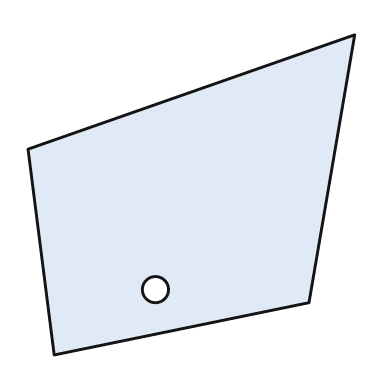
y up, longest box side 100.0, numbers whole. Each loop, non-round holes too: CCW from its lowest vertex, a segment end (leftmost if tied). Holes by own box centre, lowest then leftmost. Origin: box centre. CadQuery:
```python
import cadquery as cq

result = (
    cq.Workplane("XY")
    .moveTo(-42.0, -49.0)
    .lineTo(36.0, -33.0)
    .lineTo(50.0, 49.0)
    .lineTo(-50.0, 14.0)
    .close()
    .moveTo(-11.0, -29.0)
    .circle(4.0)
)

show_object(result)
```